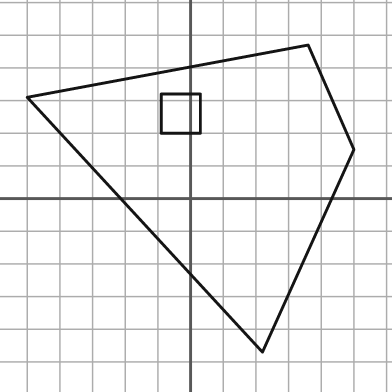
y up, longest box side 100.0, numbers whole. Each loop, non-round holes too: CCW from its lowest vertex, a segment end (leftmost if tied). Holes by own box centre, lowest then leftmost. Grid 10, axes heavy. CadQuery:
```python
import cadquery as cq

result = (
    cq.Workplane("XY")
    .moveTo(22.0, -47.0)
    .lineTo(50.0, 15.0)
    .lineTo(36.0, 47.0)
    .lineTo(-50.0, 31.0)
    .close()
    .moveTo(-9.0, 20.0)
    .lineTo(3.0, 20.0)
    .lineTo(3.0, 32.0)
    .lineTo(-9.0, 32.0)
    .close()
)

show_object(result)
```